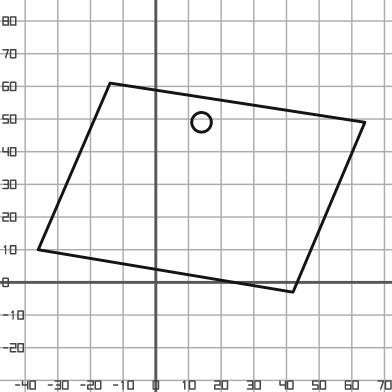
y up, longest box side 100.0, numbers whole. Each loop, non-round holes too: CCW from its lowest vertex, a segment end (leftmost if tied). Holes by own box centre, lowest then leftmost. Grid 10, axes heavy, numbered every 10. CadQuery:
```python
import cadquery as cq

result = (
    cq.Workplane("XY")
    .moveTo(42.0, -3.0)
    .lineTo(64.0, 49.0)
    .lineTo(-14.0, 61.0)
    .lineTo(-36.0, 10.0)
    .close()
    .moveTo(14.0, 49.0)
    .circle(3.0)
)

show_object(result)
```